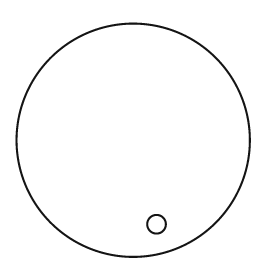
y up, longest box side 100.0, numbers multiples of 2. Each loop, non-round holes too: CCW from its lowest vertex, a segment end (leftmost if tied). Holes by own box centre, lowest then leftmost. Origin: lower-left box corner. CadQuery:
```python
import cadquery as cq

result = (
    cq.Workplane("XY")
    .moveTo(50.0, 50.0)
    .circle(50.0)
    .moveTo(60.0, 14.0)
    .circle(4.0)
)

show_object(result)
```